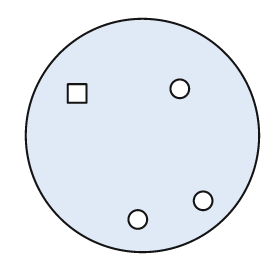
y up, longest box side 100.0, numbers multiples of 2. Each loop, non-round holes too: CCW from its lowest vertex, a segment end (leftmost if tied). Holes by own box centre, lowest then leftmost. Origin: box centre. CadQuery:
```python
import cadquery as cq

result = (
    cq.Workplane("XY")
    .moveTo(0.0, 0.0)
    .circle(50.0)
    .moveTo(-2.0, -36.0)
    .circle(4.0)
    .moveTo(26.0, -28.0)
    .circle(4.0)
    .moveTo(-32.0, 14.0)
    .lineTo(-24.0, 14.0)
    .lineTo(-24.0, 22.0)
    .lineTo(-32.0, 22.0)
    .close()
    .moveTo(16.0, 20.0)
    .circle(4.0)
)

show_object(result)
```